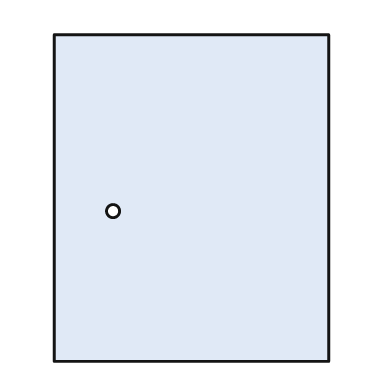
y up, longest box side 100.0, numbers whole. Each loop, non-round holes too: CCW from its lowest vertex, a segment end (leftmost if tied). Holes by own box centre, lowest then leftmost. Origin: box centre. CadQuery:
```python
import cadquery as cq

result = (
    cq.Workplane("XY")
    .moveTo(-42.0, -50.0)
    .lineTo(42.0, -50.0)
    .lineTo(42.0, 50.0)
    .lineTo(-42.0, 50.0)
    .close()
    .moveTo(-24.0, -4.0)
    .circle(2.0)
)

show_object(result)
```